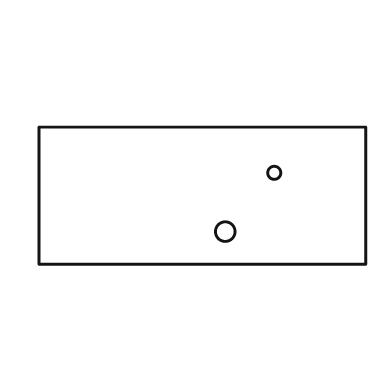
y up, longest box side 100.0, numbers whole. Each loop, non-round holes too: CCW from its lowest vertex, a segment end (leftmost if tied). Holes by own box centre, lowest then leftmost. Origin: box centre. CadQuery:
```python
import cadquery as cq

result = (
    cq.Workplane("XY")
    .moveTo(-50.0, -21.0)
    .lineTo(50.0, -21.0)
    .lineTo(50.0, 21.0)
    .lineTo(-50.0, 21.0)
    .close()
    .moveTo(7.0, -11.0)
    .circle(3.0)
    .moveTo(22.0, 7.0)
    .circle(2.0)
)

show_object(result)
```